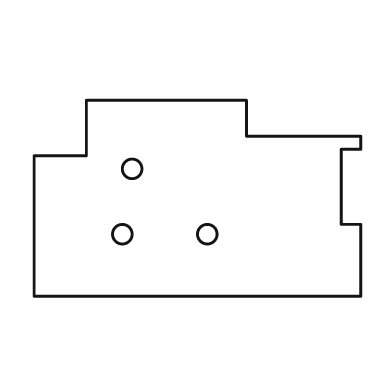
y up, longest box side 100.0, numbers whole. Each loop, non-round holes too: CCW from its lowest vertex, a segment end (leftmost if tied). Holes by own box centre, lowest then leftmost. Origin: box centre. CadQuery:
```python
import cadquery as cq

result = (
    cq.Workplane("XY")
    .moveTo(-50.0, -30.0)
    .lineTo(50.0, -30.0)
    .lineTo(50.0, -8.0)
    .lineTo(44.0, -8.0)
    .lineTo(44.0, 15.0)
    .lineTo(50.0, 15.0)
    .lineTo(50.0, 19.0)
    .lineTo(15.0, 19.0)
    .lineTo(15.0, 30.0)
    .lineTo(-34.0, 30.0)
    .lineTo(-34.0, 13.0)
    .lineTo(-50.0, 13.0)
    .close()
    .moveTo(-23.0, -11.0)
    .circle(3.0)
    .moveTo(3.0, -11.0)
    .circle(3.0)
    .moveTo(-20.0, 9.0)
    .circle(3.0)
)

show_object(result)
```